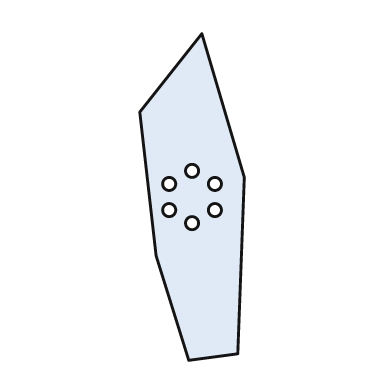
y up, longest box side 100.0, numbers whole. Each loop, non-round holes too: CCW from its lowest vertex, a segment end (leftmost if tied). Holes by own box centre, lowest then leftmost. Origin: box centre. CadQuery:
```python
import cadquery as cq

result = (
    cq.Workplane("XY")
    .moveTo(-1.0, -50.0)
    .lineTo(14.0, -48.0)
    .lineTo(16.0, 6.0)
    .lineTo(3.0, 50.0)
    .lineTo(-16.0, 26.0)
    .lineTo(-11.0, -18.0)
    .close()
    .moveTo(0.0, -8.0)
    .circle(2.0)
    .moveTo(-7.0, -4.0)
    .circle(2.0)
    .moveTo(7.0, -4.0)
    .circle(2.0)
    .moveTo(-7.0, 4.0)
    .circle(2.0)
    .moveTo(7.0, 4.0)
    .circle(2.0)
    .moveTo(0.0, 8.0)
    .circle(2.0)
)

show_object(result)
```